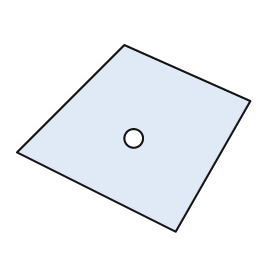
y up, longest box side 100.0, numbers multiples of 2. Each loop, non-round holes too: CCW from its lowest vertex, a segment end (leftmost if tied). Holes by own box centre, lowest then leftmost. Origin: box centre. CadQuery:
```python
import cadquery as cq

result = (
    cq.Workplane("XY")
    .moveTo(18.0, -40.0)
    .lineTo(50.0, 16.0)
    .lineTo(-4.0, 40.0)
    .lineTo(-50.0, -6.0)
    .close()
    .moveTo(0.0, 0.0)
    .circle(4.0)
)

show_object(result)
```